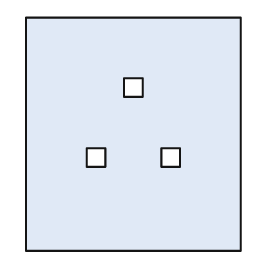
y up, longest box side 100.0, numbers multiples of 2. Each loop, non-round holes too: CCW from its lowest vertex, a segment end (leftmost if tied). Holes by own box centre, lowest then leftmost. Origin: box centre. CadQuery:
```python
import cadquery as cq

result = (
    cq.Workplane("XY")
    .moveTo(-46.0, -50.0)
    .lineTo(46.0, -50.0)
    .lineTo(46.0, 50.0)
    .lineTo(-46.0, 50.0)
    .close()
    .moveTo(-20.0, -14.0)
    .lineTo(-12.0, -14.0)
    .lineTo(-12.0, -6.0)
    .lineTo(-20.0, -6.0)
    .close()
    .moveTo(12.0, -14.0)
    .lineTo(20.0, -14.0)
    .lineTo(20.0, -6.0)
    .lineTo(12.0, -6.0)
    .close()
    .moveTo(-4.0, 16.0)
    .lineTo(4.0, 16.0)
    .lineTo(4.0, 24.0)
    .lineTo(-4.0, 24.0)
    .close()
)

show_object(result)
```